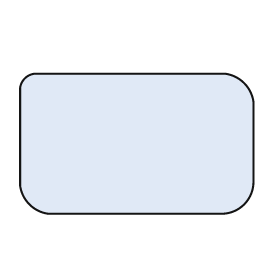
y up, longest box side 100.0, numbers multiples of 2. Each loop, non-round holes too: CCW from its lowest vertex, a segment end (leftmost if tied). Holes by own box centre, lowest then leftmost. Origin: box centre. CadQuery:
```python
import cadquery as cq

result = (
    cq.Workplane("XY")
    .moveTo(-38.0, -30.0)
    .lineTo(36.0, -30.0)
    .threePointArc((46.0, -26.0), (50.0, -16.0))
    .lineTo(50.0, 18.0)
    .threePointArc((46.0, 26.0), (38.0, 30.0))
    .lineTo(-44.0, 30.0)
    .threePointArc((-48.0, 28.0), (-50.0, 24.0))
    .lineTo(-50.0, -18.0)
    .threePointArc((-46.0, -26.0), (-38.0, -30.0))
    .close()
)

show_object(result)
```